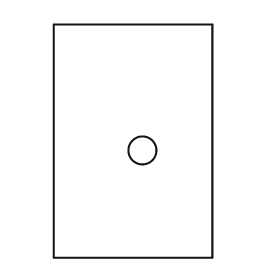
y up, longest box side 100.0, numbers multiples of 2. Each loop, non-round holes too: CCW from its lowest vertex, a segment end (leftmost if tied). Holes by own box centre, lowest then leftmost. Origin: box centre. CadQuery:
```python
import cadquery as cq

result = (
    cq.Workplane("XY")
    .moveTo(-34.0, -50.0)
    .lineTo(34.0, -50.0)
    .lineTo(34.0, 50.0)
    .lineTo(-34.0, 50.0)
    .close()
    .moveTo(4.0, -4.0)
    .circle(6.0)
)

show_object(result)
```